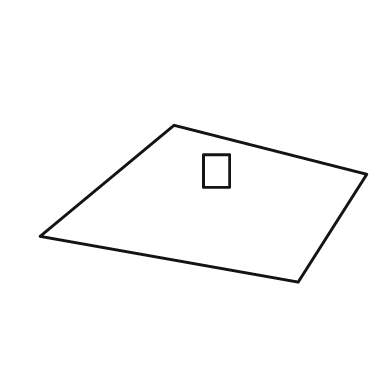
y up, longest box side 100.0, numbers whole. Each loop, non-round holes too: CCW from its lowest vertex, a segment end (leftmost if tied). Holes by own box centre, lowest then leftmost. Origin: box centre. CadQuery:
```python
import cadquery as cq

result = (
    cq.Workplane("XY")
    .moveTo(29.0, -24.0)
    .lineTo(50.0, 9.0)
    .lineTo(-9.0, 24.0)
    .lineTo(-50.0, -10.0)
    .close()
    .moveTo(0.0, 5.0)
    .lineTo(8.0, 5.0)
    .lineTo(8.0, 15.0)
    .lineTo(0.0, 15.0)
    .close()
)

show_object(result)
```